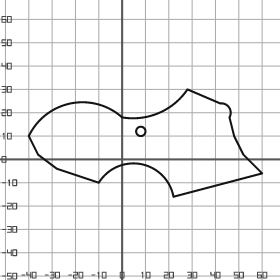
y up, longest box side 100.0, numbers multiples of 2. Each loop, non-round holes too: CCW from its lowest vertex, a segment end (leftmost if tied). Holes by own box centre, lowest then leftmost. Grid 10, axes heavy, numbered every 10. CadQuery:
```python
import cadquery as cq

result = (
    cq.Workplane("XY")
    .moveTo(22.0, -16.0)
    .lineTo(60.0, -6.0)
    .lineTo(52.0, 2.0)
    .lineTo(48.0, 10.0)
    .lineTo(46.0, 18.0)
    .threePointArc((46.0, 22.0), (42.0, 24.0))
    .lineTo(28.0, 30.0)
    .threePointArc((16.0, 20.0), (0.0, 18.0))
    .threePointArc((-22.0, 24.0), (-40.0, 10.0))
    .lineTo(-36.0, 2.0)
    .lineTo(-28.0, -4.0)
    .lineTo(-10.0, -10.0)
    .threePointArc((8.0, -2.0), (22.0, -16.0))
    .close()
    .moveTo(8.0, 12.0)
    .circle(2.0)
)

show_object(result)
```